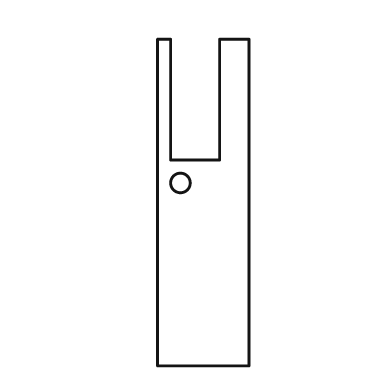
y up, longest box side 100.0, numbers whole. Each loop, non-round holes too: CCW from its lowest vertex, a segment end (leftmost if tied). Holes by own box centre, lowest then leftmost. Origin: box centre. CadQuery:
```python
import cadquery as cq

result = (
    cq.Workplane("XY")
    .moveTo(-14.0, -50.0)
    .lineTo(14.0, -50.0)
    .lineTo(14.0, 50.0)
    .lineTo(5.0, 50.0)
    .lineTo(5.0, 13.0)
    .lineTo(-10.0, 13.0)
    .lineTo(-10.0, 50.0)
    .lineTo(-14.0, 50.0)
    .close()
    .moveTo(-7.0, 6.0)
    .circle(3.0)
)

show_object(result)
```